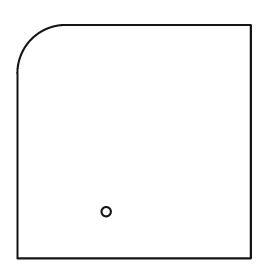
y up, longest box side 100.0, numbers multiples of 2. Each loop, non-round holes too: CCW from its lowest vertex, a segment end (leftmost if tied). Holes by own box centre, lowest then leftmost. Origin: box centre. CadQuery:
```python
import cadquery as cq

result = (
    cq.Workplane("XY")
    .moveTo(-50.0, -50.0)
    .lineTo(50.0, -50.0)
    .lineTo(50.0, 50.0)
    .lineTo(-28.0, 50.0)
    .threePointArc((-44.0, 44.0), (-50.0, 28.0))
    .close()
    .moveTo(-12.0, -30.0)
    .circle(2.0)
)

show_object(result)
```